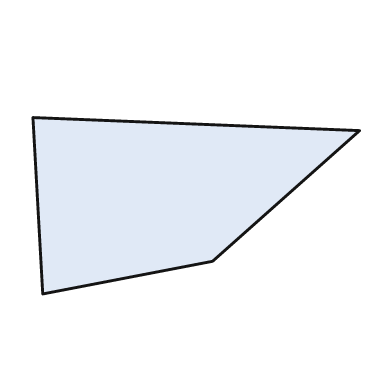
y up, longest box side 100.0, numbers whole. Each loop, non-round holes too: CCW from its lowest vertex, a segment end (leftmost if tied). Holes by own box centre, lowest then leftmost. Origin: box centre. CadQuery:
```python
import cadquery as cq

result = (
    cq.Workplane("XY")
    .moveTo(-47.0, -27.0)
    .lineTo(5.0, -17.0)
    .lineTo(50.0, 23.0)
    .lineTo(-50.0, 27.0)
    .close()
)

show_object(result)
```